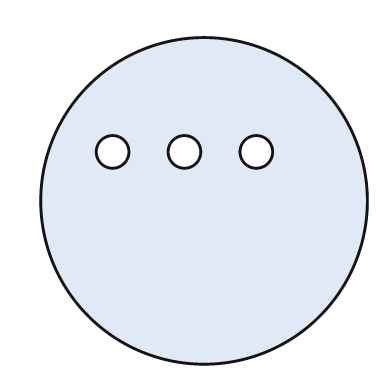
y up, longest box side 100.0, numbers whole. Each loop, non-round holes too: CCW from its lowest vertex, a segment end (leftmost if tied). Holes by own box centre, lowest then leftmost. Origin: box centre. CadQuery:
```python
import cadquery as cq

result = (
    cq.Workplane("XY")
    .moveTo(0.0, 0.0)
    .circle(50.0)
    .moveTo(-28.0, 15.0)
    .circle(5.0)
    .moveTo(-6.0, 15.0)
    .circle(5.0)
    .moveTo(16.0, 15.0)
    .circle(5.0)
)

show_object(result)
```